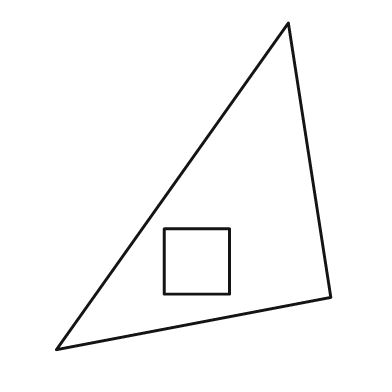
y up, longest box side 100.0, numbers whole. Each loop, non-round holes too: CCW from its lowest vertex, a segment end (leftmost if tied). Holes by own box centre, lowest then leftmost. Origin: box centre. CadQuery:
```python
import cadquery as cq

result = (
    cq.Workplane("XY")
    .moveTo(-42.0, -50.0)
    .lineTo(42.0, -34.0)
    .lineTo(29.0, 50.0)
    .close()
    .moveTo(-9.0, -33.0)
    .lineTo(11.0, -33.0)
    .lineTo(11.0, -13.0)
    .lineTo(-9.0, -13.0)
    .close()
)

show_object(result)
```